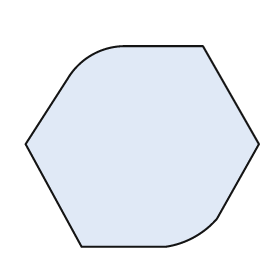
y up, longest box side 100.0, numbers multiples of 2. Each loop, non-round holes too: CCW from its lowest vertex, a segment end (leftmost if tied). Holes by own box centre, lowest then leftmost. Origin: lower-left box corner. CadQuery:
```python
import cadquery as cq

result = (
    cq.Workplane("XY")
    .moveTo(24.0, 0.0)
    .lineTo(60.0, 0.0)
    .threePointArc((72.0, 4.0), (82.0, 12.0))
    .lineTo(100.0, 44.0)
    .lineTo(76.0, 86.0)
    .lineTo(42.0, 86.0)
    .threePointArc((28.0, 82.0), (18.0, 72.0))
    .lineTo(0.0, 44.0)
    .close()
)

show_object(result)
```